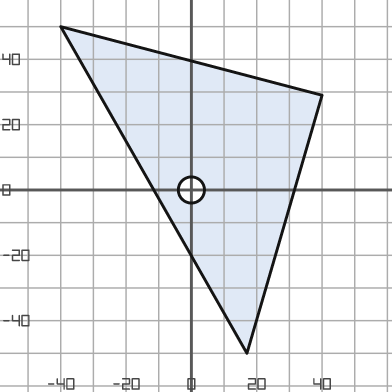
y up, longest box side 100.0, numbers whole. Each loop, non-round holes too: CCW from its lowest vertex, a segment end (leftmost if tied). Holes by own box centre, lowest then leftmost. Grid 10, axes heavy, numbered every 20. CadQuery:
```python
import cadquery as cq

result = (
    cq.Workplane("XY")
    .moveTo(17.0, -50.0)
    .lineTo(40.0, 29.0)
    .lineTo(-40.0, 50.0)
    .close()
    .moveTo(0.0, 0.0)
    .circle(4.0)
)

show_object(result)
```